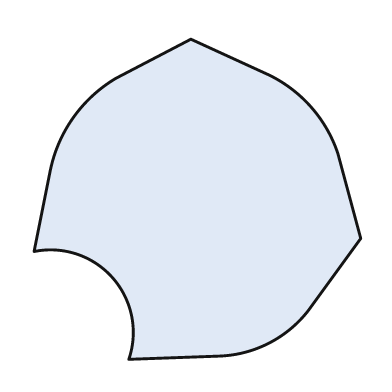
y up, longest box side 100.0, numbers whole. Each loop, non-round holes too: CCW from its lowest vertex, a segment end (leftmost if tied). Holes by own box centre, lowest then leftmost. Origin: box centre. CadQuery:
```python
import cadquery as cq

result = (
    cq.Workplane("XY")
    .moveTo(-21.0, -49.0)
    .lineTo(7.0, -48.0)
    .threePointArc((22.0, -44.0), (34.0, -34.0))
    .lineTo(50.0, -12.0)
    .lineTo(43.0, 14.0)
    .threePointArc((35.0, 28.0), (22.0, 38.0))
    .lineTo(-2.0, 49.0)
    .lineTo(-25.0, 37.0)
    .threePointArc((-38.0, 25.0), (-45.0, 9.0))
    .lineTo(-50.0, -16.0)
    .threePointArc((-26.0, -24.0), (-21.0, -49.0))
    .close()
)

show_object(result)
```